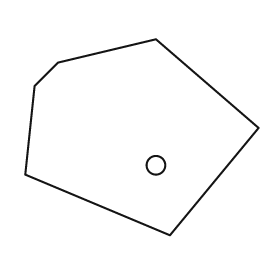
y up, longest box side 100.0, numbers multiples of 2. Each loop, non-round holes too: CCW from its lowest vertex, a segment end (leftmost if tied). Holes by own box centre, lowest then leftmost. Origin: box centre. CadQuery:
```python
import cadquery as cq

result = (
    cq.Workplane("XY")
    .moveTo(12.0, -42.0)
    .lineTo(50.0, 4.0)
    .lineTo(6.0, 42.0)
    .lineTo(-36.0, 32.0)
    .lineTo(-46.0, 22.0)
    .lineTo(-50.0, -16.0)
    .close()
    .moveTo(6.0, -12.0)
    .circle(4.0)
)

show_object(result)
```